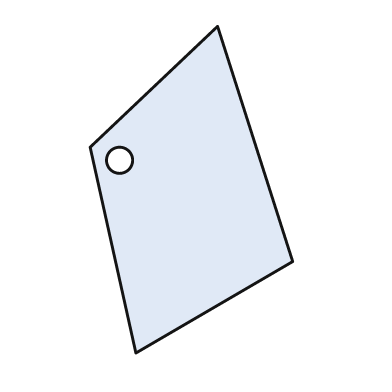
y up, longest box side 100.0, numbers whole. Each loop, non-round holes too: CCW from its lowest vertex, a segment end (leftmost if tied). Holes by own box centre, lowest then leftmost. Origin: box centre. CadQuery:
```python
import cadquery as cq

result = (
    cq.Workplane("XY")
    .moveTo(-17.0, -50.0)
    .lineTo(31.0, -22.0)
    .lineTo(8.0, 50.0)
    .lineTo(-31.0, 13.0)
    .close()
    .moveTo(-22.0, 9.0)
    .circle(4.0)
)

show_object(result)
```